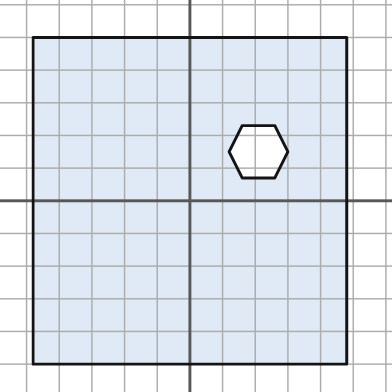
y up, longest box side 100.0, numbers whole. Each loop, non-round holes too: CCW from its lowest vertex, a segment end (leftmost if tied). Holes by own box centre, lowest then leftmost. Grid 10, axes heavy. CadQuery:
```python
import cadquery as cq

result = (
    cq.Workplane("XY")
    .moveTo(-48.0, -50.0)
    .lineTo(48.0, -50.0)
    .lineTo(48.0, 50.0)
    .lineTo(-48.0, 50.0)
    .close()
    .moveTo(16.0, 7.0)
    .lineTo(26.0, 7.0)
    .lineTo(30.0, 15.0)
    .lineTo(26.0, 23.0)
    .lineTo(16.0, 23.0)
    .lineTo(12.0, 15.0)
    .close()
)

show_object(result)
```